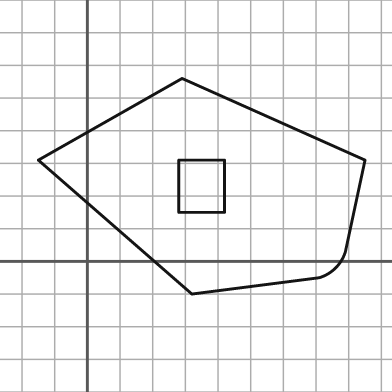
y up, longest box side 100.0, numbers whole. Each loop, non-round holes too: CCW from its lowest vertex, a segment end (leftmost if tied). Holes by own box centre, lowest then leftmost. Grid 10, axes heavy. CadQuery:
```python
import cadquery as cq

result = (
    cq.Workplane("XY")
    .moveTo(32.0, -10.0)
    .lineTo(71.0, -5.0)
    .threePointArc((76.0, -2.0), (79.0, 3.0))
    .lineTo(85.0, 31.0)
    .lineTo(29.0, 56.0)
    .lineTo(-15.0, 31.0)
    .close()
    .moveTo(28.0, 15.0)
    .lineTo(42.0, 15.0)
    .lineTo(42.0, 31.0)
    .lineTo(28.0, 31.0)
    .close()
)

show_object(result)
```